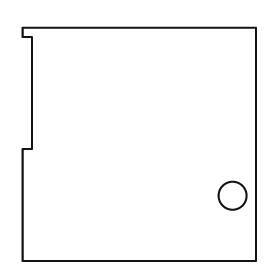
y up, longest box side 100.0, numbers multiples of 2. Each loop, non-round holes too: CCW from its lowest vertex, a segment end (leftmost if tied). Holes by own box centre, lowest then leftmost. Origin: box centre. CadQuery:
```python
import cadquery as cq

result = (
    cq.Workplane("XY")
    .moveTo(-50.0, -50.0)
    .lineTo(50.0, -50.0)
    .lineTo(50.0, 50.0)
    .lineTo(-50.0, 50.0)
    .lineTo(-50.0, 46.0)
    .lineTo(-46.0, 46.0)
    .lineTo(-46.0, -2.0)
    .lineTo(-50.0, -2.0)
    .close()
    .moveTo(40.0, -22.0)
    .circle(6.0)
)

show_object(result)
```